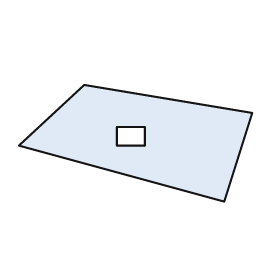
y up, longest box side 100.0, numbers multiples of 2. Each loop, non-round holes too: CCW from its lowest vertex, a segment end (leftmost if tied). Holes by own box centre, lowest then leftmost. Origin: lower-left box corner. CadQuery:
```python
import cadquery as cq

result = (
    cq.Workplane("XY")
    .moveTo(88.0, 0.0)
    .lineTo(100.0, 38.0)
    .lineTo(28.0, 50.0)
    .lineTo(0.0, 24.0)
    .close()
    .moveTo(42.0, 24.0)
    .lineTo(54.0, 24.0)
    .lineTo(54.0, 32.0)
    .lineTo(42.0, 32.0)
    .close()
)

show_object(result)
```